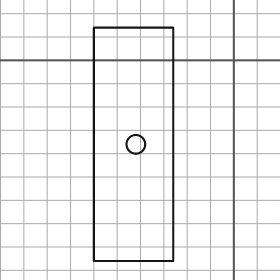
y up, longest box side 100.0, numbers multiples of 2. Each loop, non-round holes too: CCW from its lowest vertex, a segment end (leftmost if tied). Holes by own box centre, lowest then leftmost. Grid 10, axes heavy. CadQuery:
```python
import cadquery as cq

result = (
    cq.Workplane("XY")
    .moveTo(-60.0, -86.0)
    .lineTo(-26.0, -86.0)
    .lineTo(-26.0, 14.0)
    .lineTo(-60.0, 14.0)
    .close()
    .moveTo(-42.0, -36.0)
    .circle(4.0)
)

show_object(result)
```